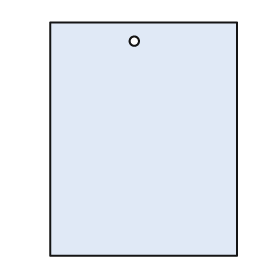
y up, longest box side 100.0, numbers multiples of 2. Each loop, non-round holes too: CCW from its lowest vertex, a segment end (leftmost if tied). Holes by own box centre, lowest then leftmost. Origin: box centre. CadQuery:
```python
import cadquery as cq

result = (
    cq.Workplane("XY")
    .moveTo(-40.0, -50.0)
    .lineTo(40.0, -50.0)
    .lineTo(40.0, 50.0)
    .lineTo(-40.0, 50.0)
    .close()
    .moveTo(-4.0, 42.0)
    .circle(2.0)
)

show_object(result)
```